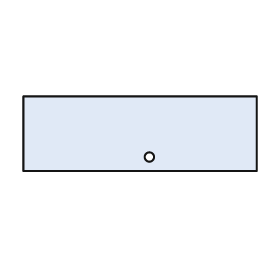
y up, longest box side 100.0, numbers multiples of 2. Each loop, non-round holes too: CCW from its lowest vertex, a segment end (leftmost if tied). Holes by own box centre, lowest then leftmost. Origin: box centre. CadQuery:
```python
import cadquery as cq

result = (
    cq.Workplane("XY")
    .moveTo(-50.0, -16.0)
    .lineTo(50.0, -16.0)
    .lineTo(50.0, 16.0)
    .lineTo(-50.0, 16.0)
    .close()
    .moveTo(4.0, -10.0)
    .circle(2.0)
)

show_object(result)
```